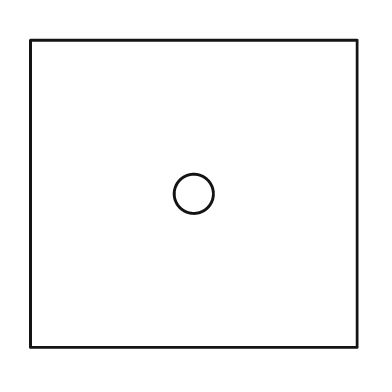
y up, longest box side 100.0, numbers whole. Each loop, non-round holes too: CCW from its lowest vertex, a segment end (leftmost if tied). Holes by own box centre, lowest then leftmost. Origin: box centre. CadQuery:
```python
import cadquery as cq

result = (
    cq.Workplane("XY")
    .moveTo(-50.0, -47.0)
    .lineTo(50.0, -47.0)
    .lineTo(50.0, 47.0)
    .lineTo(-50.0, 47.0)
    .close()
    .moveTo(0.0, 0.0)
    .circle(6.0)
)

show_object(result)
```